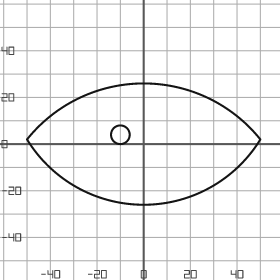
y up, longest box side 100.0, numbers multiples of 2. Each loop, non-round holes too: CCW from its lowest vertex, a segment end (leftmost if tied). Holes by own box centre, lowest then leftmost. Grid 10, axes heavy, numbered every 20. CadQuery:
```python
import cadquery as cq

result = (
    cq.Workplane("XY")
    .moveTo(-50.0, 2.0)
    .threePointArc((0.0, -26.0), (50.0, 2.0))
    .threePointArc((0.0, 26.0), (-50.0, 2.0))
    .close()
    .moveTo(-10.0, 4.0)
    .circle(4.0)
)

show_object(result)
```